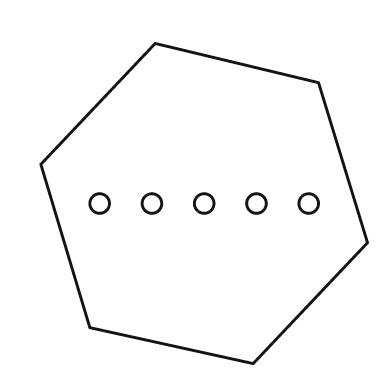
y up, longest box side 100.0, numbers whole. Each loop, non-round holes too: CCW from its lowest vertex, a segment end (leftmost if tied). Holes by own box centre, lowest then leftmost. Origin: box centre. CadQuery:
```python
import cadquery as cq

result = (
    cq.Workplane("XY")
    .moveTo(15.0, -49.0)
    .lineTo(50.0, -12.0)
    .lineTo(35.0, 37.0)
    .lineTo(-15.0, 49.0)
    .lineTo(-50.0, 12.0)
    .lineTo(-35.0, -38.0)
    .close()
    .moveTo(-32.0, 0.0)
    .circle(3.0)
    .moveTo(-16.0, 0.0)
    .circle(3.0)
    .moveTo(0.0, 0.0)
    .circle(3.0)
    .moveTo(16.0, 0.0)
    .circle(3.0)
    .moveTo(32.0, 0.0)
    .circle(3.0)
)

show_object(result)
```